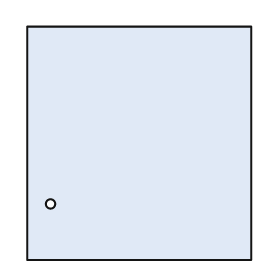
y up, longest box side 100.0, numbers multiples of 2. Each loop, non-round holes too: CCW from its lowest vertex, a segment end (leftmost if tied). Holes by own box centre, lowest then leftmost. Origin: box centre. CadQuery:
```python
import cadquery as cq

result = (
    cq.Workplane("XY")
    .moveTo(-48.0, -50.0)
    .lineTo(48.0, -50.0)
    .lineTo(48.0, 50.0)
    .lineTo(-48.0, 50.0)
    .close()
    .moveTo(-38.0, -26.0)
    .circle(2.0)
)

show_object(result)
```